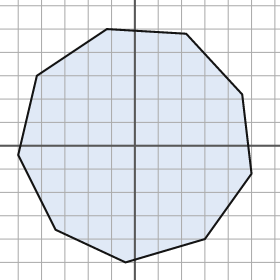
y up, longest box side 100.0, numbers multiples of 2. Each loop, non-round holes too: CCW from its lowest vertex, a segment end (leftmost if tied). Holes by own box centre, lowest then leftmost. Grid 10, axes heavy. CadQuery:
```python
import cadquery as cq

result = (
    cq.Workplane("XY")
    .moveTo(-4.0, -50.0)
    .lineTo(30.0, -40.0)
    .lineTo(50.0, -12.0)
    .lineTo(46.0, 22.0)
    .lineTo(22.0, 48.0)
    .lineTo(-12.0, 50.0)
    .lineTo(-42.0, 30.0)
    .lineTo(-50.0, -4.0)
    .lineTo(-34.0, -36.0)
    .close()
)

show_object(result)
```